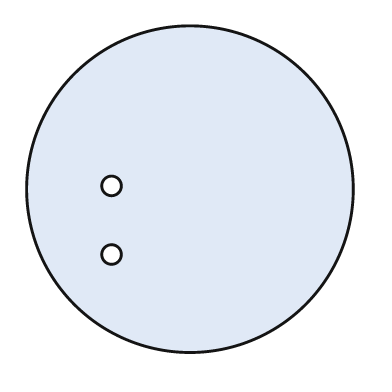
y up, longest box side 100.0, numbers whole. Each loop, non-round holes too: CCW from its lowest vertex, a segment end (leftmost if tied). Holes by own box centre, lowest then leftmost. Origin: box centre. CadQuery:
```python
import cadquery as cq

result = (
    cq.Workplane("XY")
    .moveTo(0.0, 0.0)
    .circle(50.0)
    .moveTo(-24.0, -20.0)
    .circle(3.0)
    .moveTo(-24.0, 1.0)
    .circle(3.0)
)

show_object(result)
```